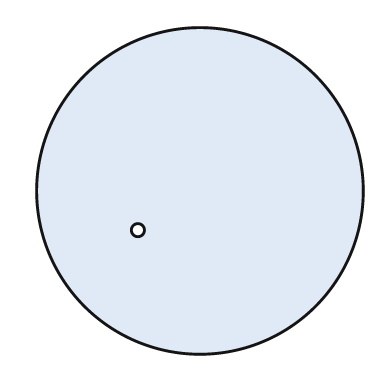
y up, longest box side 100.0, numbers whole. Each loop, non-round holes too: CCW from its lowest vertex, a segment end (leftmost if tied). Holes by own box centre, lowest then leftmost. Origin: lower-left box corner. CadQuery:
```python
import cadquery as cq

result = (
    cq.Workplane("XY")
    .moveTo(50.0, 50.0)
    .circle(50.0)
    .moveTo(31.0, 38.0)
    .circle(2.0)
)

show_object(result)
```